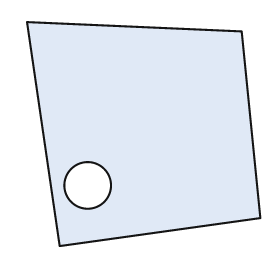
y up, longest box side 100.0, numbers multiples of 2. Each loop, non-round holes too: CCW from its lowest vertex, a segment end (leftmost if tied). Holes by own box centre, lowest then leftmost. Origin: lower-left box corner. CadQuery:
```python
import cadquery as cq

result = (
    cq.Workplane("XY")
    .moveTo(14.0, 0.0)
    .lineTo(100.0, 12.0)
    .lineTo(92.0, 92.0)
    .lineTo(0.0, 96.0)
    .close()
    .moveTo(26.0, 26.0)
    .circle(10.0)
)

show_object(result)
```